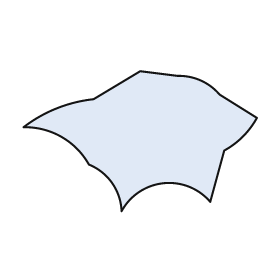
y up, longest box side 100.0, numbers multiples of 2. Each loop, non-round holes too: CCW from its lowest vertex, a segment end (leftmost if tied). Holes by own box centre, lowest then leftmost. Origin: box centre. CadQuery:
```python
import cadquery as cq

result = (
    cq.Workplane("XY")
    .moveTo(-8.0, -30.0)
    .threePointArc((10.0, -18.0), (30.0, -26.0))
    .lineTo(36.0, -4.0)
    .threePointArc((44.0, 2.0), (50.0, 10.0))
    .lineTo(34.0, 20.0)
    .threePointArc((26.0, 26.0), (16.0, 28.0))
    .lineTo(0.0, 30.0)
    .lineTo(-20.0, 18.0)
    .threePointArc((-36.0, 14.0), (-50.0, 6.0))
    .threePointArc((-34.0, 2.0), (-22.0, -10.0))
    .threePointArc((-12.0, -18.0), (-8.0, -30.0))
    .close()
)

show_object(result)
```